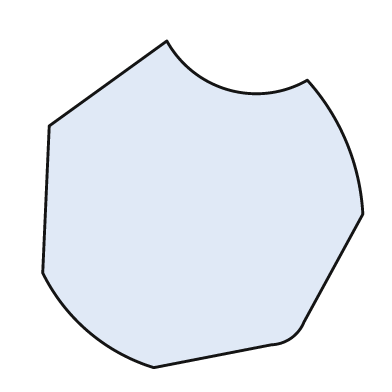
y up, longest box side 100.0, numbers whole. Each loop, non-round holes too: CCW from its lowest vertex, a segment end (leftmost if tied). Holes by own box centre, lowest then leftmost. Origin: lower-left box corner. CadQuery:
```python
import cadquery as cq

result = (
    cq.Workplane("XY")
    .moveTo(34.0, 0.0)
    .lineTo(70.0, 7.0)
    .threePointArc((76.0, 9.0), (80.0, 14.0))
    .lineTo(98.0, 47.0)
    .threePointArc((93.0, 69.0), (81.0, 88.0))
    .threePointArc((57.0, 85.0), (38.0, 100.0))
    .lineTo(2.0, 74.0)
    .lineTo(0.0, 29.0)
    .threePointArc((14.0, 11.0), (34.0, 0.0))
    .close()
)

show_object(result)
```